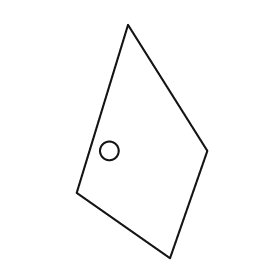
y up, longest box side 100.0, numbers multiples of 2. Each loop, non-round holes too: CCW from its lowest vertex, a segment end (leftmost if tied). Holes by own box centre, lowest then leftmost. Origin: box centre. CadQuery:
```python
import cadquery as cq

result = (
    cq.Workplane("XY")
    .moveTo(12.0, -50.0)
    .lineTo(28.0, -4.0)
    .lineTo(-6.0, 50.0)
    .lineTo(-28.0, -22.0)
    .close()
    .moveTo(-14.0, -4.0)
    .circle(4.0)
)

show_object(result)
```